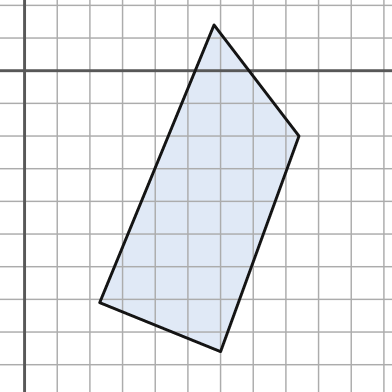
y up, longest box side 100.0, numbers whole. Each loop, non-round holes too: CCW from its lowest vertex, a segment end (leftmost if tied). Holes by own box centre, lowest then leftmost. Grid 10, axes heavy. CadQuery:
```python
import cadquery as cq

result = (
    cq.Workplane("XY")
    .moveTo(60.0, -86.0)
    .lineTo(84.0, -20.0)
    .lineTo(58.0, 14.0)
    .lineTo(23.0, -71.0)
    .close()
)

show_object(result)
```